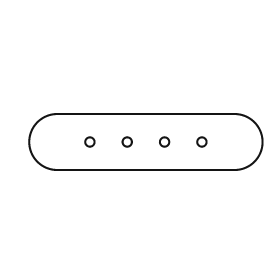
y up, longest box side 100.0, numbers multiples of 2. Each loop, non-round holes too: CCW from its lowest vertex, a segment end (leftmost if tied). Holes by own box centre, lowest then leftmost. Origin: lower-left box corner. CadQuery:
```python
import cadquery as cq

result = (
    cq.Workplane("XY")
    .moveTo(12.0, 0.0)
    .lineTo(88.0, 0.0)
    .threePointArc((100.0, 12.0), (88.0, 24.0))
    .lineTo(12.0, 24.0)
    .threePointArc((0.0, 12.0), (12.0, 0.0))
    .close()
    .moveTo(26.0, 12.0)
    .circle(2.0)
    .moveTo(42.0, 12.0)
    .circle(2.0)
    .moveTo(58.0, 12.0)
    .circle(2.0)
    .moveTo(74.0, 12.0)
    .circle(2.0)
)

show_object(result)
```